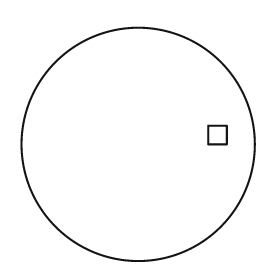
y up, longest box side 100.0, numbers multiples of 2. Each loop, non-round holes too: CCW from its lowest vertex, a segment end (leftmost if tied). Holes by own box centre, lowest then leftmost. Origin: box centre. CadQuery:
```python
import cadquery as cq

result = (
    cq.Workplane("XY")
    .moveTo(0.0, 0.0)
    .circle(50.0)
    .moveTo(30.0, 0.0)
    .lineTo(38.0, 0.0)
    .lineTo(38.0, 8.0)
    .lineTo(30.0, 8.0)
    .close()
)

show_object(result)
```